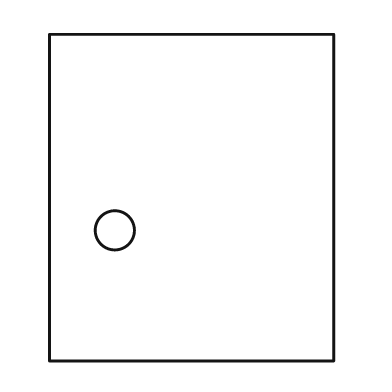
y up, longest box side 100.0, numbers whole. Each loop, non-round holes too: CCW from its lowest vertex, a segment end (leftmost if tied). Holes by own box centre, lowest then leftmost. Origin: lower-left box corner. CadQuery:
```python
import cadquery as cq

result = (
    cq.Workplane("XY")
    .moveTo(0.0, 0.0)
    .lineTo(87.0, 0.0)
    .lineTo(87.0, 100.0)
    .lineTo(0.0, 100.0)
    .close()
    .moveTo(20.0, 40.0)
    .circle(6.0)
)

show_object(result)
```